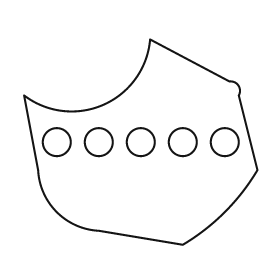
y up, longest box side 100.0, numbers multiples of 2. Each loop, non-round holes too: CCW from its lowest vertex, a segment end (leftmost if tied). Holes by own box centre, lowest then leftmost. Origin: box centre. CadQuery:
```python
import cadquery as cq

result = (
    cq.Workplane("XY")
    .moveTo(18.0, -44.0)
    .threePointArc((36.0, -30.0), (50.0, -12.0))
    .lineTo(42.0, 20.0)
    .threePointArc((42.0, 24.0), (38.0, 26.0))
    .lineTo(4.0, 44.0)
    .threePointArc((-16.0, 16.0), (-50.0, 20.0))
    .lineTo(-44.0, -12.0)
    .threePointArc((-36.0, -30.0), (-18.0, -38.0))
    .close()
    .moveTo(-36.0, 0.0)
    .circle(6.0)
    .moveTo(-18.0, 0.0)
    .circle(6.0)
    .moveTo(0.0, 0.0)
    .circle(6.0)
    .moveTo(18.0, 0.0)
    .circle(6.0)
    .moveTo(36.0, 0.0)
    .circle(6.0)
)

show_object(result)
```